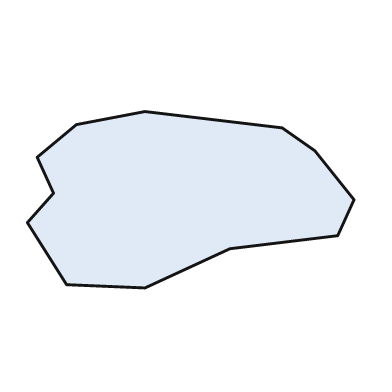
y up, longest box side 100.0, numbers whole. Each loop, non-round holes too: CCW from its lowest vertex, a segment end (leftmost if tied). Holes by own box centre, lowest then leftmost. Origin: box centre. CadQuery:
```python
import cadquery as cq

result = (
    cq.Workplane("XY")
    .moveTo(-14.0, -27.0)
    .lineTo(12.0, -15.0)
    .lineTo(45.0, -11.0)
    .lineTo(50.0, 0.0)
    .lineTo(38.0, 15.0)
    .lineTo(28.0, 22.0)
    .lineTo(-14.0, 27.0)
    .lineTo(-35.0, 23.0)
    .lineTo(-47.0, 13.0)
    .lineTo(-42.0, 2.0)
    .lineTo(-50.0, -7.0)
    .lineTo(-38.0, -26.0)
    .close()
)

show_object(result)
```